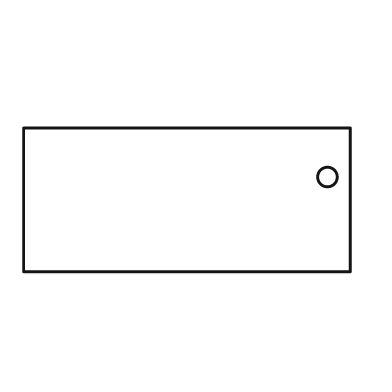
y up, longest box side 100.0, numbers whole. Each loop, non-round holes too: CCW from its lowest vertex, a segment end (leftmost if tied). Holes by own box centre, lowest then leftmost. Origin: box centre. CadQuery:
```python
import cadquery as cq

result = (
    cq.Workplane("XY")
    .moveTo(-50.0, -22.0)
    .lineTo(50.0, -22.0)
    .lineTo(50.0, 22.0)
    .lineTo(-50.0, 22.0)
    .close()
    .moveTo(43.0, 7.0)
    .circle(3.0)
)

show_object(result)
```